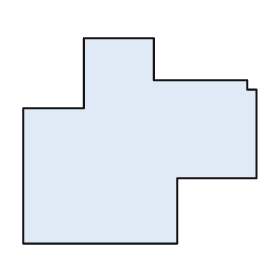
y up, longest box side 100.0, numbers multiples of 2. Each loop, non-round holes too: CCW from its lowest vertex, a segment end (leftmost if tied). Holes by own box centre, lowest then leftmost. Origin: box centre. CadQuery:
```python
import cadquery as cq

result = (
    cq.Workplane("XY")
    .moveTo(-50.0, -44.0)
    .lineTo(16.0, -44.0)
    .lineTo(16.0, -16.0)
    .lineTo(50.0, -16.0)
    .lineTo(50.0, 22.0)
    .lineTo(46.0, 22.0)
    .lineTo(46.0, 26.0)
    .lineTo(6.0, 26.0)
    .lineTo(6.0, 44.0)
    .lineTo(-24.0, 44.0)
    .lineTo(-24.0, 14.0)
    .lineTo(-50.0, 14.0)
    .close()
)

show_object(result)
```